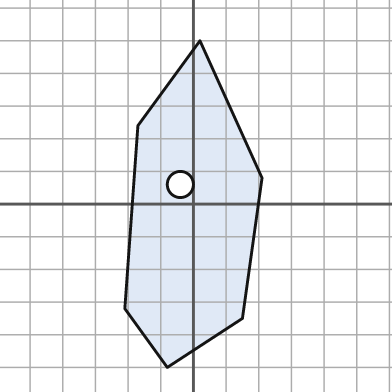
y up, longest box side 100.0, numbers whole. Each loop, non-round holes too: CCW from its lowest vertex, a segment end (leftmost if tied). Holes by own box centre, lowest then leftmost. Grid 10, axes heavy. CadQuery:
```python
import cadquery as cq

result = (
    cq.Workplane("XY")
    .moveTo(-8.0, -50.0)
    .lineTo(15.0, -35.0)
    .lineTo(21.0, 8.0)
    .lineTo(2.0, 50.0)
    .lineTo(-17.0, 24.0)
    .lineTo(-21.0, -32.0)
    .close()
    .moveTo(-4.0, 6.0)
    .circle(4.0)
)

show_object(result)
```